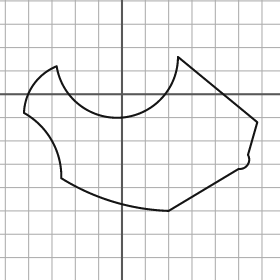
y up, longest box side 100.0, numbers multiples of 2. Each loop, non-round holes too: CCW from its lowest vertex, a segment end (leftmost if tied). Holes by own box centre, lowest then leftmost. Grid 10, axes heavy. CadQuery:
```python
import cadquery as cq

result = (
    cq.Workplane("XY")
    .moveTo(20.0, -50.0)
    .lineTo(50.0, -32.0)
    .threePointArc((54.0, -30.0), (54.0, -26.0))
    .lineTo(58.0, -12.0)
    .lineTo(24.0, 16.0)
    .threePointArc((0.0, -10.0), (-28.0, 12.0))
    .threePointArc((-38.0, 4.0), (-42.0, -8.0))
    .threePointArc((-30.0, -20.0), (-26.0, -36.0))
    .threePointArc((-4.0, -46.0), (20.0, -50.0))
    .close()
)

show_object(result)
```